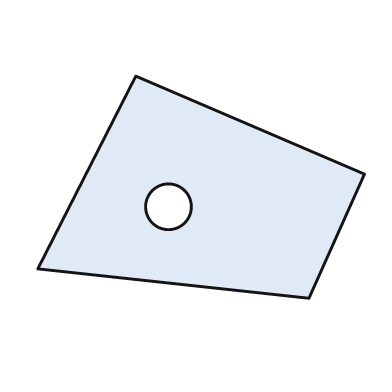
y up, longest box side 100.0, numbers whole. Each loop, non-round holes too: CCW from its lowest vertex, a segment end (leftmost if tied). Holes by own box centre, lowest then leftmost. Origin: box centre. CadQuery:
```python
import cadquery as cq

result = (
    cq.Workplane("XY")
    .moveTo(33.0, -34.0)
    .lineTo(50.0, 4.0)
    .lineTo(-20.0, 34.0)
    .lineTo(-50.0, -25.0)
    .close()
    .moveTo(-10.0, -6.0)
    .circle(7.0)
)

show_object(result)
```